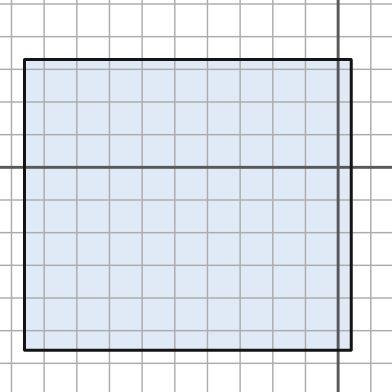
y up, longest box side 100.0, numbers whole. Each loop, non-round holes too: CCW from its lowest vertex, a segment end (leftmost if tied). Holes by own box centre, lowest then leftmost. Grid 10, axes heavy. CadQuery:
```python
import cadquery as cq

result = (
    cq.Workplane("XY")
    .moveTo(-96.0, -56.0)
    .lineTo(4.0, -56.0)
    .lineTo(4.0, 33.0)
    .lineTo(-96.0, 33.0)
    .close()
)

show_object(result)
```